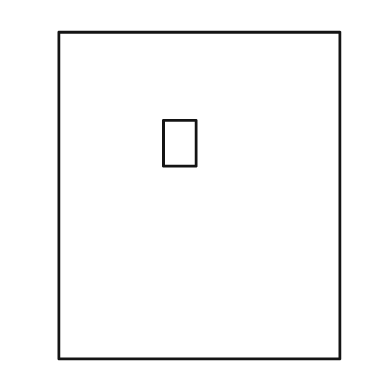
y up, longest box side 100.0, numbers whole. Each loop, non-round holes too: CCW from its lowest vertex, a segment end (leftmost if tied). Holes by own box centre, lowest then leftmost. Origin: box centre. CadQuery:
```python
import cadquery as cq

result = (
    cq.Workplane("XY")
    .moveTo(-43.0, -50.0)
    .lineTo(43.0, -50.0)
    .lineTo(43.0, 50.0)
    .lineTo(-43.0, 50.0)
    .close()
    .moveTo(-11.0, 9.0)
    .lineTo(-1.0, 9.0)
    .lineTo(-1.0, 23.0)
    .lineTo(-11.0, 23.0)
    .close()
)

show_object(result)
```